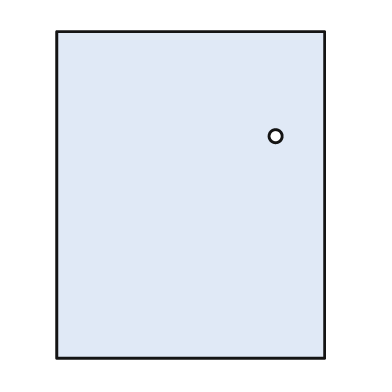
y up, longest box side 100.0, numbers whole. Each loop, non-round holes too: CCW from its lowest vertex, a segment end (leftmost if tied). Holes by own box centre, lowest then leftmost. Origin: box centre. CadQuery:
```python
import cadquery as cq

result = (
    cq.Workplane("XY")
    .moveTo(-41.0, -50.0)
    .lineTo(41.0, -50.0)
    .lineTo(41.0, 50.0)
    .lineTo(-41.0, 50.0)
    .close()
    .moveTo(26.0, 18.0)
    .circle(2.0)
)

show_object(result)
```